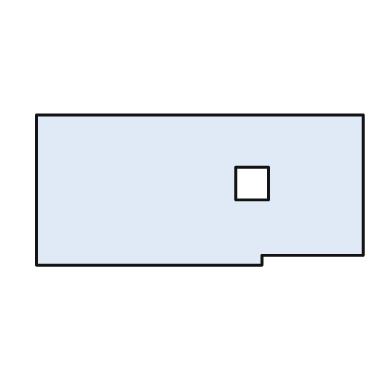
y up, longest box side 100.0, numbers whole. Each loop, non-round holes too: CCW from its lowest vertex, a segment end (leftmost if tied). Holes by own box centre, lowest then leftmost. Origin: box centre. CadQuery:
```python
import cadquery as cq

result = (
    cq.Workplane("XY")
    .moveTo(-50.0, -23.0)
    .lineTo(19.0, -23.0)
    .lineTo(19.0, -20.0)
    .lineTo(50.0, -20.0)
    .lineTo(50.0, 23.0)
    .lineTo(-50.0, 23.0)
    .close()
    .moveTo(11.0, -3.0)
    .lineTo(21.0, -3.0)
    .lineTo(21.0, 7.0)
    .lineTo(11.0, 7.0)
    .close()
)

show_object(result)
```